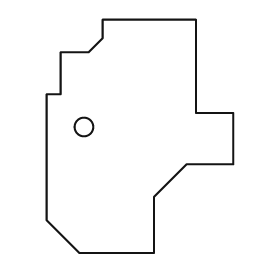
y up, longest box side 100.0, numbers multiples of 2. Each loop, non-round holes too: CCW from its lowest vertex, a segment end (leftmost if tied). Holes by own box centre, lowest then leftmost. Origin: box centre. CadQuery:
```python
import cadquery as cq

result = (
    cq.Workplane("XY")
    .moveTo(-26.0, -50.0)
    .lineTo(6.0, -50.0)
    .lineTo(6.0, -26.0)
    .lineTo(20.0, -12.0)
    .lineTo(40.0, -12.0)
    .lineTo(40.0, 10.0)
    .lineTo(24.0, 10.0)
    .lineTo(24.0, 50.0)
    .lineTo(-16.0, 50.0)
    .lineTo(-16.0, 42.0)
    .lineTo(-22.0, 36.0)
    .lineTo(-34.0, 36.0)
    .lineTo(-34.0, 18.0)
    .lineTo(-40.0, 18.0)
    .lineTo(-40.0, -36.0)
    .close()
    .moveTo(-24.0, 4.0)
    .circle(4.0)
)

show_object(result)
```